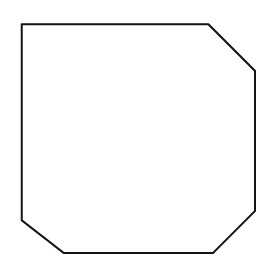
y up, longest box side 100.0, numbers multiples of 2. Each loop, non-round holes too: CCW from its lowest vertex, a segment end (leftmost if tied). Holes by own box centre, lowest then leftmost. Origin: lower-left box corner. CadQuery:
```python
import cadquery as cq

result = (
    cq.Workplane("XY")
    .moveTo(18.0, 0.0)
    .lineTo(82.0, 0.0)
    .lineTo(100.0, 18.0)
    .lineTo(100.0, 78.0)
    .lineTo(80.0, 98.0)
    .lineTo(0.0, 98.0)
    .lineTo(0.0, 14.0)
    .close()
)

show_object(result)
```